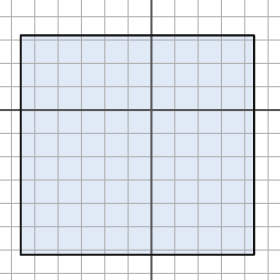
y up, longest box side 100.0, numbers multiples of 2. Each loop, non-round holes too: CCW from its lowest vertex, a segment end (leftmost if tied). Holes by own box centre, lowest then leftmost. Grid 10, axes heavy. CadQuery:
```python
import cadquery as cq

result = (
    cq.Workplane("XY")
    .moveTo(-56.0, -62.0)
    .lineTo(44.0, -62.0)
    .lineTo(44.0, 32.0)
    .lineTo(-56.0, 32.0)
    .close()
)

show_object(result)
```